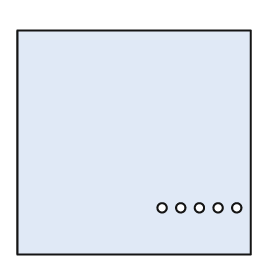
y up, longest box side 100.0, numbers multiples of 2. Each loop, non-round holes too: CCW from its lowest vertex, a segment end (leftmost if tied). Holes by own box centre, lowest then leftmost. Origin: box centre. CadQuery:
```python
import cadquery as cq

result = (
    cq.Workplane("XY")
    .moveTo(-50.0, -48.0)
    .lineTo(50.0, -48.0)
    .lineTo(50.0, 48.0)
    .lineTo(-50.0, 48.0)
    .close()
    .moveTo(12.0, -28.0)
    .circle(2.0)
    .moveTo(20.0, -28.0)
    .circle(2.0)
    .moveTo(28.0, -28.0)
    .circle(2.0)
    .moveTo(36.0, -28.0)
    .circle(2.0)
    .moveTo(44.0, -28.0)
    .circle(2.0)
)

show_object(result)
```